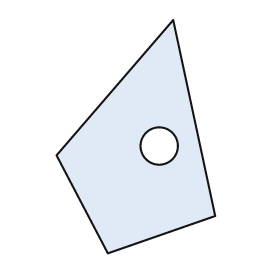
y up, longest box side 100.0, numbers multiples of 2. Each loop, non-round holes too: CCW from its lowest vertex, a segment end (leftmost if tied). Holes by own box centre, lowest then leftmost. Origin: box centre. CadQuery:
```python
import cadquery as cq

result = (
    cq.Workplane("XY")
    .moveTo(-12.0, -50.0)
    .lineTo(34.0, -34.0)
    .lineTo(16.0, 50.0)
    .lineTo(-34.0, -8.0)
    .close()
    .moveTo(10.0, -4.0)
    .circle(8.0)
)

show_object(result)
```